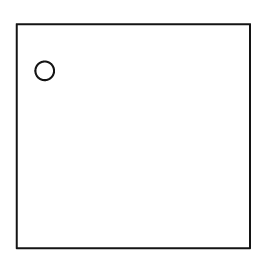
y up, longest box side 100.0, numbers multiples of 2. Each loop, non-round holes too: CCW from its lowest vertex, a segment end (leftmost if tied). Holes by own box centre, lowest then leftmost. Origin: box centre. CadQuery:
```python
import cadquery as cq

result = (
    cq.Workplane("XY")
    .moveTo(-50.0, -48.0)
    .lineTo(50.0, -48.0)
    .lineTo(50.0, 48.0)
    .lineTo(-50.0, 48.0)
    .close()
    .moveTo(-38.0, 28.0)
    .circle(4.0)
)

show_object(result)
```